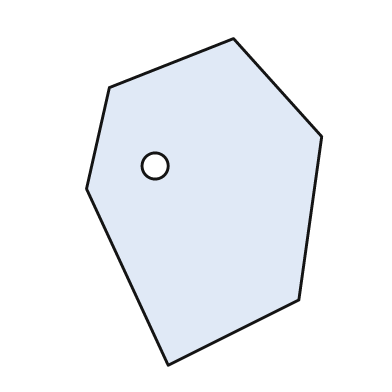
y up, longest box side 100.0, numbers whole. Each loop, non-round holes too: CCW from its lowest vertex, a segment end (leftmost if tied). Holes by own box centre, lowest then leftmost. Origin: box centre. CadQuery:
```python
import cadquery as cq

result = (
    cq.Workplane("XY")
    .moveTo(-11.0, -50.0)
    .lineTo(29.0, -30.0)
    .lineTo(36.0, 20.0)
    .lineTo(9.0, 50.0)
    .lineTo(-29.0, 35.0)
    .lineTo(-36.0, 4.0)
    .close()
    .moveTo(-15.0, 11.0)
    .circle(4.0)
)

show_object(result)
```